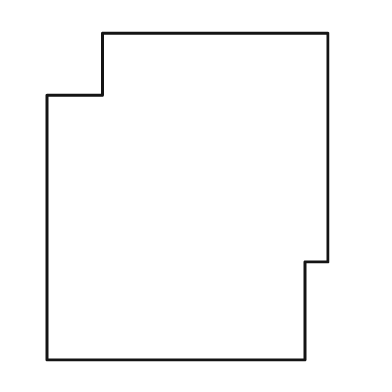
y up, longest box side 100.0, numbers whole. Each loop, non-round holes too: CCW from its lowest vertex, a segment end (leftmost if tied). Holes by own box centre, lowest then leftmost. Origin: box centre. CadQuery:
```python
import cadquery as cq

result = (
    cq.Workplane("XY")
    .moveTo(-43.0, -50.0)
    .lineTo(36.0, -50.0)
    .lineTo(36.0, -20.0)
    .lineTo(43.0, -20.0)
    .lineTo(43.0, 50.0)
    .lineTo(-26.0, 50.0)
    .lineTo(-26.0, 31.0)
    .lineTo(-43.0, 31.0)
    .close()
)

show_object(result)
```